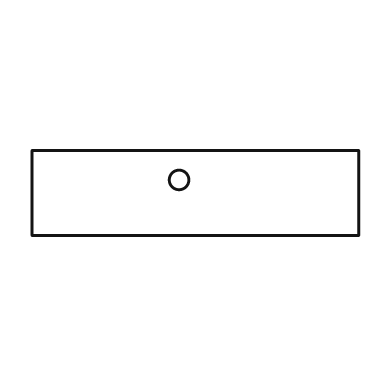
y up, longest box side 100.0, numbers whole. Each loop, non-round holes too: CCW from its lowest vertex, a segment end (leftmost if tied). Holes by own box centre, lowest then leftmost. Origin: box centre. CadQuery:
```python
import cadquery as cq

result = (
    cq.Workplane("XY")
    .moveTo(-50.0, -13.0)
    .lineTo(50.0, -13.0)
    .lineTo(50.0, 13.0)
    .lineTo(-50.0, 13.0)
    .close()
    .moveTo(-5.0, 4.0)
    .circle(3.0)
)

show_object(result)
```